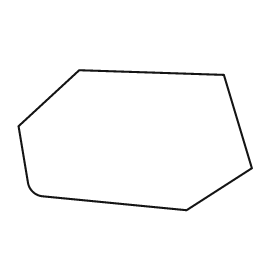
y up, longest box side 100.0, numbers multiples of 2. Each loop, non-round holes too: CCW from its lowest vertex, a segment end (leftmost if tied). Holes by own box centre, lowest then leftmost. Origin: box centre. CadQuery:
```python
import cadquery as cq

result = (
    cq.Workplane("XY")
    .moveTo(22.0, -30.0)
    .lineTo(50.0, -12.0)
    .lineTo(38.0, 28.0)
    .lineTo(-24.0, 30.0)
    .lineTo(-50.0, 6.0)
    .lineTo(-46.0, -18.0)
    .threePointArc((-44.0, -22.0), (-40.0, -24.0))
    .close()
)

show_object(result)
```